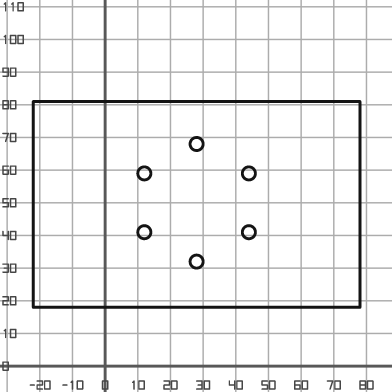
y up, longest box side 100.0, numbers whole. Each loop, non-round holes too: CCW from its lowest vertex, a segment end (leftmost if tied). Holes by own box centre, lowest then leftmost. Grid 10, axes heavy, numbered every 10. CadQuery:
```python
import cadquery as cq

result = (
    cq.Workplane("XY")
    .moveTo(-22.0, 18.0)
    .lineTo(78.0, 18.0)
    .lineTo(78.0, 81.0)
    .lineTo(-22.0, 81.0)
    .close()
    .moveTo(28.0, 32.0)
    .circle(2.0)
    .moveTo(12.0, 41.0)
    .circle(2.0)
    .moveTo(44.0, 41.0)
    .circle(2.0)
    .moveTo(12.0, 59.0)
    .circle(2.0)
    .moveTo(44.0, 59.0)
    .circle(2.0)
    .moveTo(28.0, 68.0)
    .circle(2.0)
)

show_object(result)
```